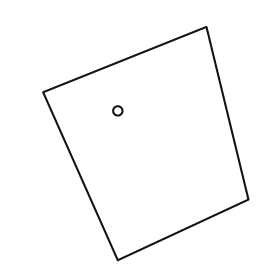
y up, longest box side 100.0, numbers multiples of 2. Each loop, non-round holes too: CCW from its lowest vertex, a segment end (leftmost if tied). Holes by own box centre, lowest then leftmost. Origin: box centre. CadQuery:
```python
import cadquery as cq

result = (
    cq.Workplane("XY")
    .moveTo(-12.0, -50.0)
    .lineTo(44.0, -24.0)
    .lineTo(26.0, 50.0)
    .lineTo(-44.0, 22.0)
    .close()
    .moveTo(-12.0, 14.0)
    .circle(2.0)
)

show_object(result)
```